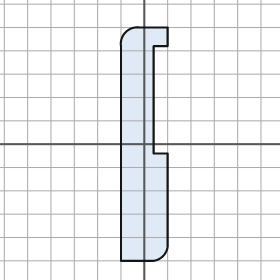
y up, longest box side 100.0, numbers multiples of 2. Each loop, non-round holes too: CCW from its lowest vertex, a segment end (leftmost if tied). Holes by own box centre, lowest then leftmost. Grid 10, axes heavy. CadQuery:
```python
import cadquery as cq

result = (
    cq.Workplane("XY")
    .moveTo(-10.0, -50.0)
    .lineTo(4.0, -50.0)
    .threePointArc((8.0, -48.0), (10.0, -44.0))
    .lineTo(10.0, -4.0)
    .lineTo(4.0, -4.0)
    .lineTo(4.0, 42.0)
    .lineTo(10.0, 42.0)
    .lineTo(10.0, 50.0)
    .lineTo(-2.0, 50.0)
    .threePointArc((-8.0, 48.0), (-10.0, 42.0))
    .close()
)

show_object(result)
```